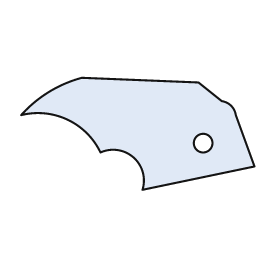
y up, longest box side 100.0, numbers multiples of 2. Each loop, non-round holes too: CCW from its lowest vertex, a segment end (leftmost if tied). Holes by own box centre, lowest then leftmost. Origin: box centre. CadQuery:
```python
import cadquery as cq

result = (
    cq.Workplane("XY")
    .moveTo(2.0, -24.0)
    .lineTo(50.0, -14.0)
    .lineTo(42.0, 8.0)
    .threePointArc((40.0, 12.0), (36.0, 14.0))
    .lineTo(26.0, 22.0)
    .lineTo(-24.0, 24.0)
    .threePointArc((-38.0, 18.0), (-50.0, 8.0))
    .threePointArc((-30.0, 6.0), (-16.0, -8.0))
    .threePointArc((-2.0, -10.0), (2.0, -24.0))
    .close()
    .moveTo(28.0, -4.0)
    .circle(4.0)
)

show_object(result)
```